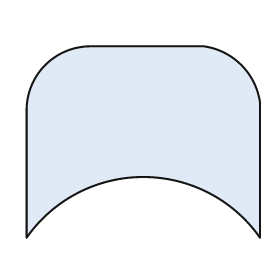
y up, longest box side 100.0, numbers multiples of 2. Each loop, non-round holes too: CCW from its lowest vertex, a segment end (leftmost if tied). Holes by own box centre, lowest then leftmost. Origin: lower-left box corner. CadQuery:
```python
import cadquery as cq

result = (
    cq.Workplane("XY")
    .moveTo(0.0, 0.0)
    .threePointArc((50.0, 26.0), (100.0, 0.0))
    .lineTo(100.0, 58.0)
    .threePointArc((92.0, 74.0), (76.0, 82.0))
    .lineTo(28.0, 82.0)
    .threePointArc((8.0, 74.0), (0.0, 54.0))
    .close()
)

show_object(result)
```